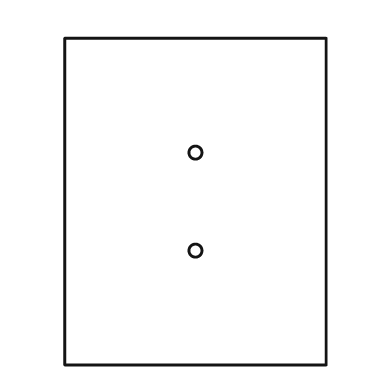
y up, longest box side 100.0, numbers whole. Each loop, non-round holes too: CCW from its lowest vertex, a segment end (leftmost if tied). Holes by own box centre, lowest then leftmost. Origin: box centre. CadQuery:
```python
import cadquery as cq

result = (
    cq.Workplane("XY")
    .moveTo(-40.0, -50.0)
    .lineTo(40.0, -50.0)
    .lineTo(40.0, 50.0)
    .lineTo(-40.0, 50.0)
    .close()
    .moveTo(0.0, -15.0)
    .circle(2.0)
    .moveTo(0.0, 15.0)
    .circle(2.0)
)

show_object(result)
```